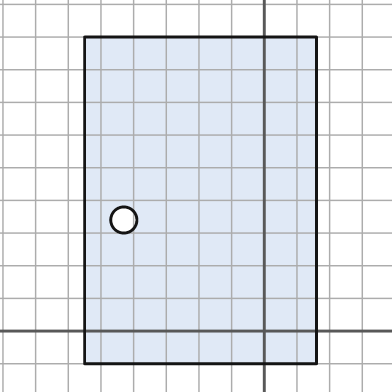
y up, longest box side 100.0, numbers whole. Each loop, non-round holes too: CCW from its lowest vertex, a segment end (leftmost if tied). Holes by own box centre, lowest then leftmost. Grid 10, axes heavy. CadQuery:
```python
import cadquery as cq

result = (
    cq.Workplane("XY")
    .moveTo(-55.0, -10.0)
    .lineTo(16.0, -10.0)
    .lineTo(16.0, 90.0)
    .lineTo(-55.0, 90.0)
    .close()
    .moveTo(-43.0, 34.0)
    .circle(4.0)
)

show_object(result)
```